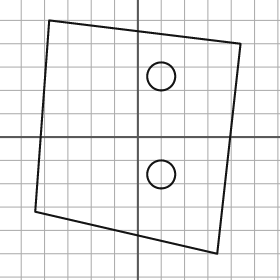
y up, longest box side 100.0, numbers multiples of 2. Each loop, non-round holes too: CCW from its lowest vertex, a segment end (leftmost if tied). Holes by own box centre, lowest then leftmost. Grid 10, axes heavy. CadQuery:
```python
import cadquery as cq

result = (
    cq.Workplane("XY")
    .moveTo(34.0, -50.0)
    .lineTo(44.0, 40.0)
    .lineTo(-38.0, 50.0)
    .lineTo(-44.0, -32.0)
    .close()
    .moveTo(10.0, -16.0)
    .circle(6.0)
    .moveTo(10.0, 26.0)
    .circle(6.0)
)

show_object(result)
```